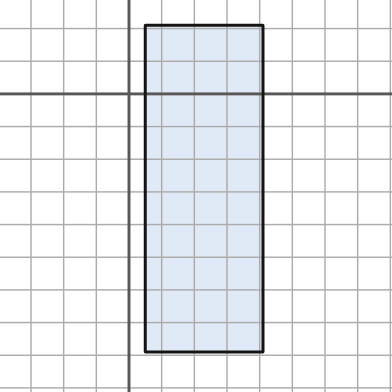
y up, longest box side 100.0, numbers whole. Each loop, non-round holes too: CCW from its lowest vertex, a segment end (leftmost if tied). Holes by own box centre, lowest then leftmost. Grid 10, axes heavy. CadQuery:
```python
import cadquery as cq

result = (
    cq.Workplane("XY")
    .moveTo(5.0, -79.0)
    .lineTo(41.0, -79.0)
    .lineTo(41.0, 21.0)
    .lineTo(5.0, 21.0)
    .close()
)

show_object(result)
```